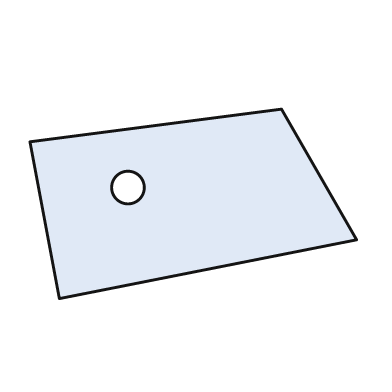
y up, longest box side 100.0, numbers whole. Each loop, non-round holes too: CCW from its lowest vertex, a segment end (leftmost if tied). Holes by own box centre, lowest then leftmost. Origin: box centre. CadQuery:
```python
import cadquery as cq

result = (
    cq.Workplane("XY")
    .moveTo(-41.0, -29.0)
    .lineTo(50.0, -11.0)
    .lineTo(27.0, 29.0)
    .lineTo(-50.0, 19.0)
    .close()
    .moveTo(-20.0, 5.0)
    .circle(5.0)
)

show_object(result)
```